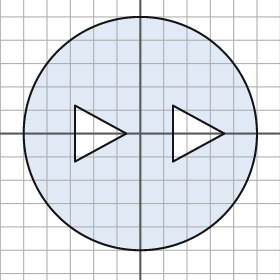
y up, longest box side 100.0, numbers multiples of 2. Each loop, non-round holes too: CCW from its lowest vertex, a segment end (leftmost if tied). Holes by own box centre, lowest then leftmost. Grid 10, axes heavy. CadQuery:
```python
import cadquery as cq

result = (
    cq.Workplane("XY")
    .moveTo(0.0, 0.0)
    .circle(50.0)
    .moveTo(-28.0, -12.0)
    .lineTo(-6.0, 0.0)
    .lineTo(-28.0, 12.0)
    .close()
    .moveTo(14.0, -12.0)
    .lineTo(36.0, 0.0)
    .lineTo(14.0, 12.0)
    .close()
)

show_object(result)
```